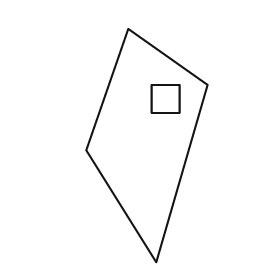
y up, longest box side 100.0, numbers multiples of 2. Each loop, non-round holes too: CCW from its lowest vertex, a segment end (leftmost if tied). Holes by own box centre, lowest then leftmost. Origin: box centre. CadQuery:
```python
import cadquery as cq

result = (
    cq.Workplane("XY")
    .moveTo(4.0, -50.0)
    .lineTo(26.0, 26.0)
    .lineTo(-8.0, 50.0)
    .lineTo(-26.0, -2.0)
    .close()
    .moveTo(2.0, 14.0)
    .lineTo(14.0, 14.0)
    .lineTo(14.0, 26.0)
    .lineTo(2.0, 26.0)
    .close()
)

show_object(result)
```